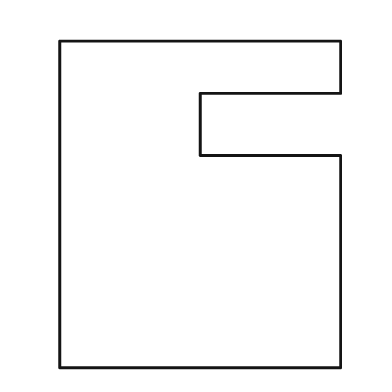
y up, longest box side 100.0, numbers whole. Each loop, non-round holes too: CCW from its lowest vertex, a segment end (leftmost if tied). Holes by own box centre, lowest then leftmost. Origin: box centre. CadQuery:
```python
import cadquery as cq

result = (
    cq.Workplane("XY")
    .moveTo(-43.0, -50.0)
    .lineTo(43.0, -50.0)
    .lineTo(43.0, 15.0)
    .lineTo(0.0, 15.0)
    .lineTo(0.0, 34.0)
    .lineTo(43.0, 34.0)
    .lineTo(43.0, 50.0)
    .lineTo(-43.0, 50.0)
    .close()
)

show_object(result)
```